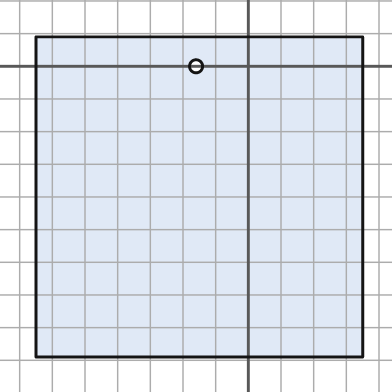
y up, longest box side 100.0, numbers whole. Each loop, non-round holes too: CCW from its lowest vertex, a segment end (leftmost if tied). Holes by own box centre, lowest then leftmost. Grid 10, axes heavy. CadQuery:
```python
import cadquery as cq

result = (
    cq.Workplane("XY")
    .moveTo(-65.0, -89.0)
    .lineTo(35.0, -89.0)
    .lineTo(35.0, 9.0)
    .lineTo(-65.0, 9.0)
    .close()
    .moveTo(-16.0, 0.0)
    .circle(2.0)
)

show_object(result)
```